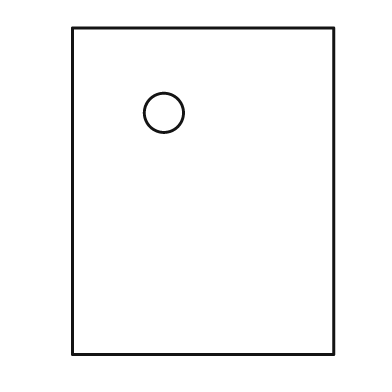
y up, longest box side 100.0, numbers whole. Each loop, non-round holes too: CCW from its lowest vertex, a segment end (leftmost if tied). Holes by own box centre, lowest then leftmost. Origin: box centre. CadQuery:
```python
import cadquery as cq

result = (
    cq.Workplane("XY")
    .moveTo(-40.0, -50.0)
    .lineTo(40.0, -50.0)
    .lineTo(40.0, 50.0)
    .lineTo(-40.0, 50.0)
    .close()
    .moveTo(-12.0, 24.0)
    .circle(6.0)
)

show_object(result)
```